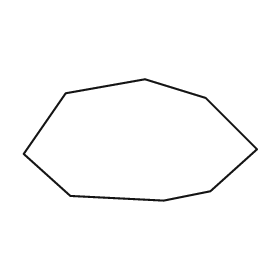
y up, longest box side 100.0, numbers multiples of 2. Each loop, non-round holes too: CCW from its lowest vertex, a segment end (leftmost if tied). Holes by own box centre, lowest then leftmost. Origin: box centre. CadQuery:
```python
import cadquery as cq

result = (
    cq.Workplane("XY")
    .moveTo(10.0, -26.0)
    .lineTo(30.0, -22.0)
    .lineTo(50.0, -4.0)
    .lineTo(28.0, 18.0)
    .lineTo(2.0, 26.0)
    .lineTo(-32.0, 20.0)
    .lineTo(-50.0, -6.0)
    .lineTo(-30.0, -24.0)
    .close()
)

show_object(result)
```